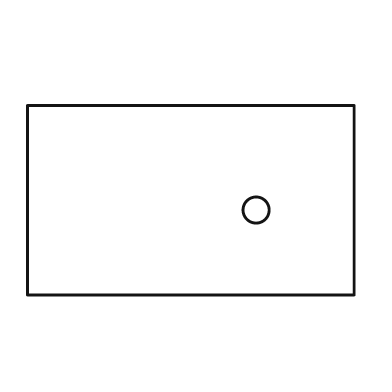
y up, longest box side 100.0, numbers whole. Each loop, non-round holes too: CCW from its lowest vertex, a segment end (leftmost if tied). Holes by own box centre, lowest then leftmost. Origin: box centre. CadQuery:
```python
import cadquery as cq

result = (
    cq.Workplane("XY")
    .moveTo(-50.0, -29.0)
    .lineTo(50.0, -29.0)
    .lineTo(50.0, 29.0)
    .lineTo(-50.0, 29.0)
    .close()
    .moveTo(20.0, -3.0)
    .circle(4.0)
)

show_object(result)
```